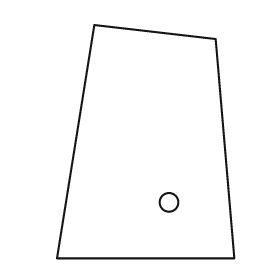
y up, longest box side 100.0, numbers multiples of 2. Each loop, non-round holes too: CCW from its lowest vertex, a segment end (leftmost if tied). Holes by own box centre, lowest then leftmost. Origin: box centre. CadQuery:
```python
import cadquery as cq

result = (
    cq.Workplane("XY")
    .moveTo(-38.0, -50.0)
    .lineTo(38.0, -50.0)
    .lineTo(30.0, 44.0)
    .lineTo(-22.0, 50.0)
    .close()
    .moveTo(10.0, -26.0)
    .circle(4.0)
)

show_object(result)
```